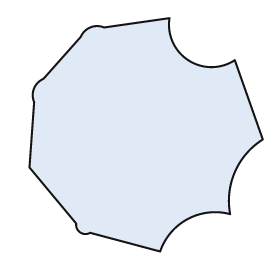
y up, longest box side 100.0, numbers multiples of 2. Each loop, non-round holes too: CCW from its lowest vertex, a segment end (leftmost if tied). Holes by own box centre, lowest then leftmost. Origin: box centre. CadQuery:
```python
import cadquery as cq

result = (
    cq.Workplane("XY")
    .moveTo(6.0, -50.0)
    .threePointArc((18.0, -36.0), (36.0, -34.0))
    .threePointArc((38.0, -16.0), (50.0, -2.0))
    .lineTo(38.0, 32.0)
    .threePointArc((18.0, 32.0), (10.0, 50.0))
    .lineTo(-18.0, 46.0)
    .threePointArc((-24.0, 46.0), (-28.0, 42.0))
    .lineTo(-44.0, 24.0)
    .threePointArc((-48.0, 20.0), (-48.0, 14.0))
    .lineTo(-50.0, -14.0)
    .lineTo(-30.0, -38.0)
    .threePointArc((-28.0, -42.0), (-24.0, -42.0))
    .close()
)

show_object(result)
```